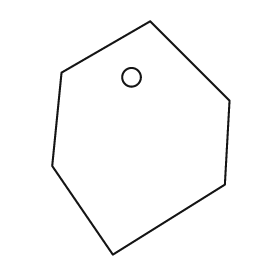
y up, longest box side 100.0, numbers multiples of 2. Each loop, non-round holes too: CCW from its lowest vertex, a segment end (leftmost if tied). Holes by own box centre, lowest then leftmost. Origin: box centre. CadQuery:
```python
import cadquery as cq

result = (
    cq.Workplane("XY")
    .moveTo(-12.0, -50.0)
    .lineTo(36.0, -20.0)
    .lineTo(38.0, 16.0)
    .lineTo(4.0, 50.0)
    .lineTo(-34.0, 28.0)
    .lineTo(-38.0, -12.0)
    .close()
    .moveTo(-4.0, 26.0)
    .circle(4.0)
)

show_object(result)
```